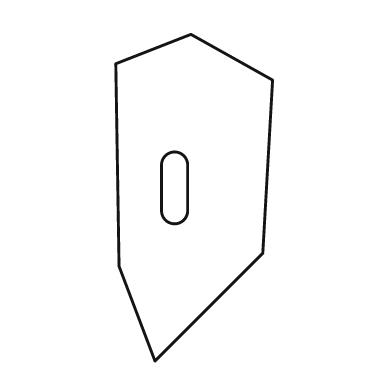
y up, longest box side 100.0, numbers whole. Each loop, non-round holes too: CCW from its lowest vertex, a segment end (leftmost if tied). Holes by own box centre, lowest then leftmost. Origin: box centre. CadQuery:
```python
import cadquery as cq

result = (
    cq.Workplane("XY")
    .moveTo(-12.0, -50.0)
    .lineTo(21.0, -17.0)
    .lineTo(24.0, 36.0)
    .lineTo(-1.0, 50.0)
    .lineTo(-24.0, 41.0)
    .lineTo(-23.0, -21.0)
    .close()
    .moveTo(-10.0, -4.0)
    .threePointArc((-6.0, -8.0), (-2.0, -4.0))
    .lineTo(-2.0, 10.0)
    .threePointArc((-6.0, 14.0), (-10.0, 10.0))
    .close()
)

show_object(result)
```